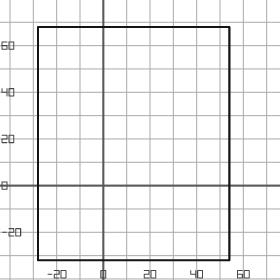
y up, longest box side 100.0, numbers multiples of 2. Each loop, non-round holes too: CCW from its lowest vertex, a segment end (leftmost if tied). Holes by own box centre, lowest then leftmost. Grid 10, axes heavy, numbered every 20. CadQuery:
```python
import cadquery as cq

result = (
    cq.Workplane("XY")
    .moveTo(-28.0, -32.0)
    .lineTo(54.0, -32.0)
    .lineTo(54.0, 68.0)
    .lineTo(-28.0, 68.0)
    .close()
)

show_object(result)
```